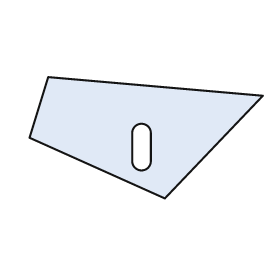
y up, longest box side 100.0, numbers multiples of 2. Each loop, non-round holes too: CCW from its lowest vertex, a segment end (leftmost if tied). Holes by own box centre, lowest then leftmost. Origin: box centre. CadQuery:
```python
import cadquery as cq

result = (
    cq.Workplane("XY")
    .moveTo(8.0, -26.0)
    .lineTo(50.0, 18.0)
    .lineTo(-42.0, 26.0)
    .lineTo(-50.0, 0.0)
    .close()
    .moveTo(-6.0, -10.0)
    .threePointArc((-2.0, -14.0), (2.0, -10.0))
    .lineTo(2.0, 2.0)
    .threePointArc((-2.0, 6.0), (-6.0, 2.0))
    .close()
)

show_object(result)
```